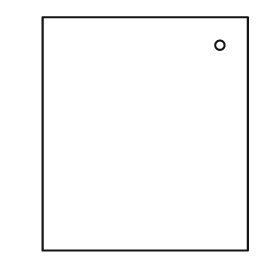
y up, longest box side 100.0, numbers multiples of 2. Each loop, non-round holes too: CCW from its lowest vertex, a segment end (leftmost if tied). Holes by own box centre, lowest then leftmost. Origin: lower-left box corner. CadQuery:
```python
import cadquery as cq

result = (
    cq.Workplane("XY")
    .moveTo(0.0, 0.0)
    .lineTo(88.0, 0.0)
    .lineTo(88.0, 100.0)
    .lineTo(0.0, 100.0)
    .close()
    .moveTo(76.0, 88.0)
    .circle(2.0)
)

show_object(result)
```